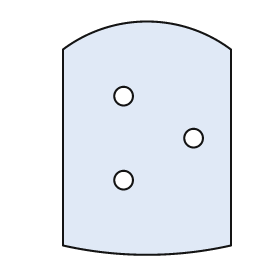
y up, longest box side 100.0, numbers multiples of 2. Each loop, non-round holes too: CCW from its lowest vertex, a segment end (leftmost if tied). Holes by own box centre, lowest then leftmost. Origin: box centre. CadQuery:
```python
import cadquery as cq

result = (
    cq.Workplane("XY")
    .moveTo(-36.0, -46.0)
    .threePointArc((0.0, -50.0), (36.0, -46.0))
    .lineTo(36.0, 38.0)
    .threePointArc((0.0, 50.0), (-36.0, 38.0))
    .close()
    .moveTo(-10.0, -18.0)
    .circle(4.0)
    .moveTo(20.0, 0.0)
    .circle(4.0)
    .moveTo(-10.0, 18.0)
    .circle(4.0)
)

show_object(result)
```